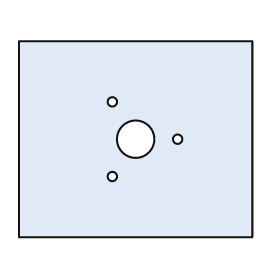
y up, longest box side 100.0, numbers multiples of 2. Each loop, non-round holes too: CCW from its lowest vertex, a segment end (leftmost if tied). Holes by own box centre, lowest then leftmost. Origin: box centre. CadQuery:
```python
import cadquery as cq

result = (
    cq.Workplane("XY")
    .moveTo(-50.0, -42.0)
    .lineTo(50.0, -42.0)
    .lineTo(50.0, 42.0)
    .lineTo(-50.0, 42.0)
    .close()
    .moveTo(-10.0, -16.0)
    .circle(2.0)
    .moveTo(0.0, 0.0)
    .circle(8.0)
    .moveTo(18.0, 0.0)
    .circle(2.0)
    .moveTo(-10.0, 16.0)
    .circle(2.0)
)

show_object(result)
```